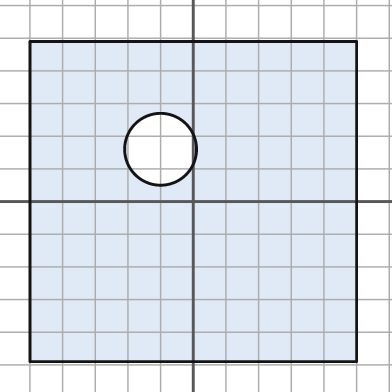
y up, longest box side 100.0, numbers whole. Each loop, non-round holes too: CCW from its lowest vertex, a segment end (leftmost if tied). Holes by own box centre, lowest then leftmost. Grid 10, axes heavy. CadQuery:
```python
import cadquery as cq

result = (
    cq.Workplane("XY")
    .moveTo(-50.0, -49.0)
    .lineTo(50.0, -49.0)
    .lineTo(50.0, 49.0)
    .lineTo(-50.0, 49.0)
    .close()
    .moveTo(-10.0, 16.0)
    .circle(11.0)
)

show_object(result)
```